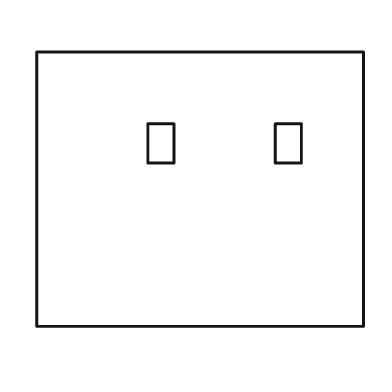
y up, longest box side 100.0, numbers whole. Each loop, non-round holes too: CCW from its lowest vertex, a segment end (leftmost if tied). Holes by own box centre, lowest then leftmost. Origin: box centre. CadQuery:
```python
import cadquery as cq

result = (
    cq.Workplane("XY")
    .moveTo(-50.0, -42.0)
    .lineTo(50.0, -42.0)
    .lineTo(50.0, 42.0)
    .lineTo(-50.0, 42.0)
    .close()
    .moveTo(-16.0, 8.0)
    .lineTo(-8.0, 8.0)
    .lineTo(-8.0, 20.0)
    .lineTo(-16.0, 20.0)
    .close()
    .moveTo(23.0, 8.0)
    .lineTo(31.0, 8.0)
    .lineTo(31.0, 20.0)
    .lineTo(23.0, 20.0)
    .close()
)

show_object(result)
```